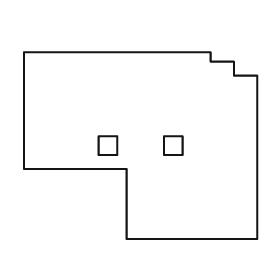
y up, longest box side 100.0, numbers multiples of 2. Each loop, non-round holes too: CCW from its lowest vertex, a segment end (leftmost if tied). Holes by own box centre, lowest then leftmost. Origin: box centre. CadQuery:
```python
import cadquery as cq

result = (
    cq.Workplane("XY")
    .moveTo(-6.0, -40.0)
    .lineTo(50.0, -40.0)
    .lineTo(50.0, 30.0)
    .lineTo(40.0, 30.0)
    .lineTo(40.0, 36.0)
    .lineTo(30.0, 36.0)
    .lineTo(30.0, 40.0)
    .lineTo(-50.0, 40.0)
    .lineTo(-50.0, -10.0)
    .lineTo(-6.0, -10.0)
    .close()
    .moveTo(-18.0, -4.0)
    .lineTo(-10.0, -4.0)
    .lineTo(-10.0, 4.0)
    .lineTo(-18.0, 4.0)
    .close()
    .moveTo(10.0, -4.0)
    .lineTo(18.0, -4.0)
    .lineTo(18.0, 4.0)
    .lineTo(10.0, 4.0)
    .close()
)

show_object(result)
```